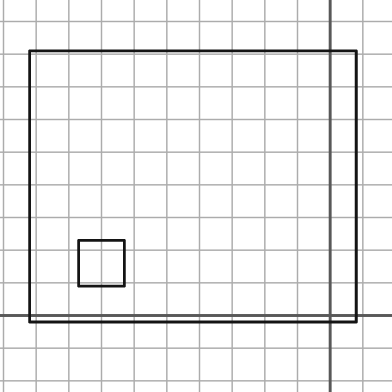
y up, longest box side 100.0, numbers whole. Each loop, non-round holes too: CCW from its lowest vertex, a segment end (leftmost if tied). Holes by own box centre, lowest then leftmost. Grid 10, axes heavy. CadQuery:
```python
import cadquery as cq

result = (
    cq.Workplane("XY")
    .moveTo(-92.0, -2.0)
    .lineTo(8.0, -2.0)
    .lineTo(8.0, 81.0)
    .lineTo(-92.0, 81.0)
    .close()
    .moveTo(-77.0, 9.0)
    .lineTo(-63.0, 9.0)
    .lineTo(-63.0, 23.0)
    .lineTo(-77.0, 23.0)
    .close()
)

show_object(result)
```